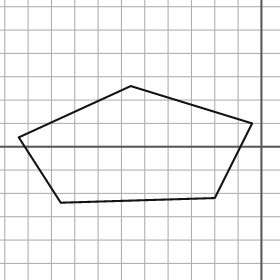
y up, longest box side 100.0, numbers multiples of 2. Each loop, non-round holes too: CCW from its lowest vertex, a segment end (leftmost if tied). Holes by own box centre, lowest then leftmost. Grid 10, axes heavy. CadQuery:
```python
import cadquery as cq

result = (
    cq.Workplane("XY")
    .moveTo(-86.0, -24.0)
    .lineTo(-20.0, -22.0)
    .lineTo(-4.0, 10.0)
    .lineTo(-56.0, 26.0)
    .lineTo(-104.0, 4.0)
    .close()
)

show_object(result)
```